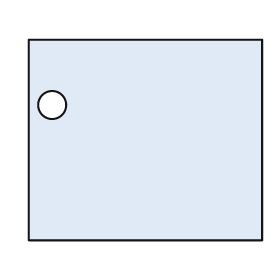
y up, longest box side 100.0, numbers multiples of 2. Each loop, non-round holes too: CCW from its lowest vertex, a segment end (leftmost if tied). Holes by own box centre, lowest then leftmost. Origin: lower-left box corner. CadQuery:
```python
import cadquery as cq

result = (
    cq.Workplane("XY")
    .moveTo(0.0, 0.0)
    .lineTo(100.0, 0.0)
    .lineTo(100.0, 86.0)
    .lineTo(0.0, 86.0)
    .close()
    .moveTo(10.0, 58.0)
    .circle(6.0)
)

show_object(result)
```